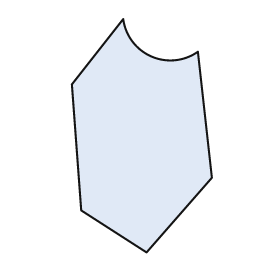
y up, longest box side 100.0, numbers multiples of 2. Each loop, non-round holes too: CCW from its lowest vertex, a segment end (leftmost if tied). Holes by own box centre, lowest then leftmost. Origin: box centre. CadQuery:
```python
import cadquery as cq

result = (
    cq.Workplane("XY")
    .moveTo(2.0, -50.0)
    .lineTo(30.0, -18.0)
    .lineTo(24.0, 36.0)
    .threePointArc((4.0, 34.0), (-8.0, 50.0))
    .lineTo(-30.0, 22.0)
    .lineTo(-26.0, -32.0)
    .close()
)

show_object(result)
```